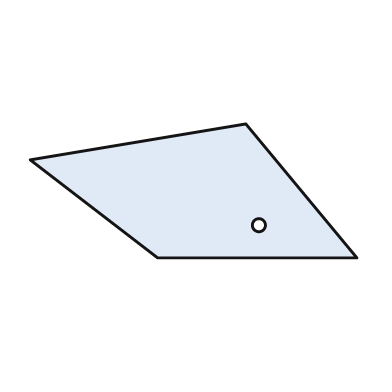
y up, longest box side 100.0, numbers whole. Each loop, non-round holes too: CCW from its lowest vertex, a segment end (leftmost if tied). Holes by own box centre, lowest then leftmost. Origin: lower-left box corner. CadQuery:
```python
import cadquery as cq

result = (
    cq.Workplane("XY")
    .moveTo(39.0, 0.0)
    .lineTo(100.0, 0.0)
    .lineTo(66.0, 41.0)
    .lineTo(0.0, 30.0)
    .close()
    .moveTo(70.0, 10.0)
    .circle(2.0)
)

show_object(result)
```